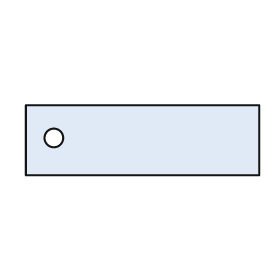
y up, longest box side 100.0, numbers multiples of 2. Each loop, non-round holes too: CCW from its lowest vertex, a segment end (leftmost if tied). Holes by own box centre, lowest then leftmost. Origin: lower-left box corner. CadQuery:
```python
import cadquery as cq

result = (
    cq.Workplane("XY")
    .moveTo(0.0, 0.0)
    .lineTo(100.0, 0.0)
    .lineTo(100.0, 30.0)
    .lineTo(0.0, 30.0)
    .close()
    .moveTo(12.0, 16.0)
    .circle(4.0)
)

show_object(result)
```